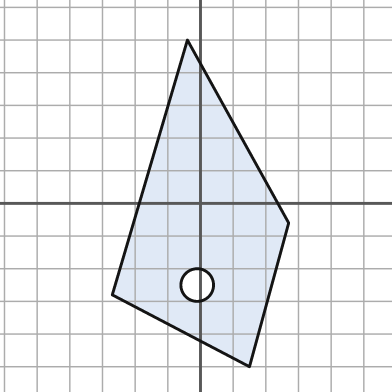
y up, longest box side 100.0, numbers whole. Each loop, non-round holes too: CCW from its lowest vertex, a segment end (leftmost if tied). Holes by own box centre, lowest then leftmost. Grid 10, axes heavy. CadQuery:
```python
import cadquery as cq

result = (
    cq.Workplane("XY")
    .moveTo(15.0, -50.0)
    .lineTo(27.0, -6.0)
    .lineTo(-4.0, 50.0)
    .lineTo(-27.0, -28.0)
    .close()
    .moveTo(-1.0, -25.0)
    .circle(5.0)
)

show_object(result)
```